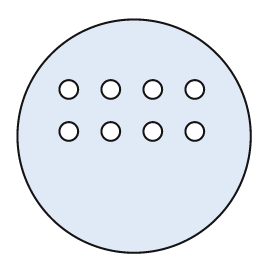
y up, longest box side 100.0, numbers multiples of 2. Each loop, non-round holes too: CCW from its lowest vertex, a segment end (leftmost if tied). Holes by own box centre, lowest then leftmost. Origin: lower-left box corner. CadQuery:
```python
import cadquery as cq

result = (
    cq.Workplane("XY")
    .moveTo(50.0, 50.0)
    .circle(50.0)
    .moveTo(22.0, 52.0)
    .circle(4.0)
    .moveTo(40.0, 52.0)
    .circle(4.0)
    .moveTo(58.0, 52.0)
    .circle(4.0)
    .moveTo(76.0, 52.0)
    .circle(4.0)
    .moveTo(22.0, 70.0)
    .circle(4.0)
    .moveTo(40.0, 70.0)
    .circle(4.0)
    .moveTo(58.0, 70.0)
    .circle(4.0)
    .moveTo(76.0, 70.0)
    .circle(4.0)
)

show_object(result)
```